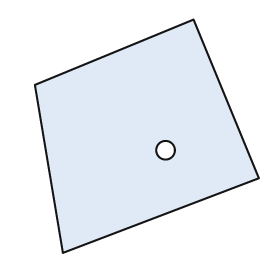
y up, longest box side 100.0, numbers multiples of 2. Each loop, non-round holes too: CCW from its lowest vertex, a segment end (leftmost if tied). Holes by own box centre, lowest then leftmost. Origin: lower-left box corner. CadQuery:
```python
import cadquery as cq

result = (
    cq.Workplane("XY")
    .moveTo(12.0, 0.0)
    .lineTo(96.0, 32.0)
    .lineTo(68.0, 100.0)
    .lineTo(0.0, 72.0)
    .close()
    .moveTo(56.0, 44.0)
    .circle(4.0)
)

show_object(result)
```